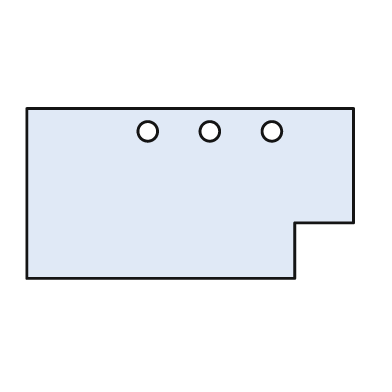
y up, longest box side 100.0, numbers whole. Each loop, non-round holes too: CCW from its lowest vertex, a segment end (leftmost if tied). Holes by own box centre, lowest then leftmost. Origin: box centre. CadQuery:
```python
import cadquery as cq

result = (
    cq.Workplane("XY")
    .moveTo(-50.0, -26.0)
    .lineTo(32.0, -26.0)
    .lineTo(32.0, -9.0)
    .lineTo(50.0, -9.0)
    .lineTo(50.0, 26.0)
    .lineTo(-50.0, 26.0)
    .close()
    .moveTo(-13.0, 19.0)
    .circle(3.0)
    .moveTo(6.0, 19.0)
    .circle(3.0)
    .moveTo(25.0, 19.0)
    .circle(3.0)
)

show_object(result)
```